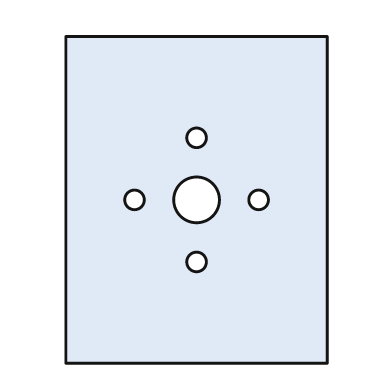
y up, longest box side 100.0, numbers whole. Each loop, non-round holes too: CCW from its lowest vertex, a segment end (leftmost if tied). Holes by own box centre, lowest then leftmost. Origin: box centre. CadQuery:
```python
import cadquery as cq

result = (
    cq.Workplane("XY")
    .moveTo(-40.0, -50.0)
    .lineTo(40.0, -50.0)
    .lineTo(40.0, 50.0)
    .lineTo(-40.0, 50.0)
    .close()
    .moveTo(0.0, -19.0)
    .circle(3.0)
    .moveTo(-19.0, 0.0)
    .circle(3.0)
    .moveTo(0.0, 0.0)
    .circle(7.0)
    .moveTo(19.0, 0.0)
    .circle(3.0)
    .moveTo(0.0, 19.0)
    .circle(3.0)
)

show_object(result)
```